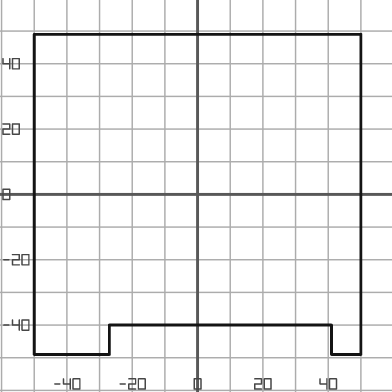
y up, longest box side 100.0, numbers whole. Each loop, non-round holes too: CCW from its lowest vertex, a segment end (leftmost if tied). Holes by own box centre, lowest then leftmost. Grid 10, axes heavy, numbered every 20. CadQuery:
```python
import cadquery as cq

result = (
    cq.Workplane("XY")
    .moveTo(-50.0, -49.0)
    .lineTo(-27.0, -49.0)
    .lineTo(-27.0, -40.0)
    .lineTo(41.0, -40.0)
    .lineTo(41.0, -49.0)
    .lineTo(50.0, -49.0)
    .lineTo(50.0, 49.0)
    .lineTo(-50.0, 49.0)
    .close()
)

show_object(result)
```